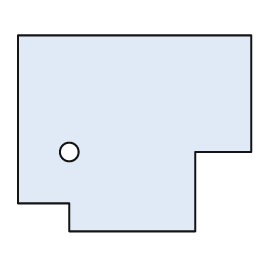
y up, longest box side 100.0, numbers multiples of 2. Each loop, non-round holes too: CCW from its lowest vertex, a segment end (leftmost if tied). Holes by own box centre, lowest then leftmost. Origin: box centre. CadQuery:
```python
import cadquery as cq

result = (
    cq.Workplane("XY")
    .moveTo(-28.0, -42.0)
    .lineTo(26.0, -42.0)
    .lineTo(26.0, -8.0)
    .lineTo(50.0, -8.0)
    .lineTo(50.0, 42.0)
    .lineTo(-50.0, 42.0)
    .lineTo(-50.0, -30.0)
    .lineTo(-28.0, -30.0)
    .close()
    .moveTo(-28.0, -8.0)
    .circle(4.0)
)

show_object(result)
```